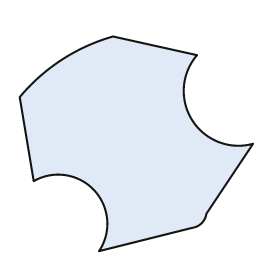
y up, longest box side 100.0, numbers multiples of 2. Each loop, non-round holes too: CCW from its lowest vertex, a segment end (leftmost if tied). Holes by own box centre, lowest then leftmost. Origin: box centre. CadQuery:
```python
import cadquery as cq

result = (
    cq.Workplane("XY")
    .moveTo(-16.0, -46.0)
    .lineTo(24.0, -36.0)
    .threePointArc((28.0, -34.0), (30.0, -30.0))
    .lineTo(50.0, 0.0)
    .threePointArc((24.0, 10.0), (26.0, 38.0))
    .lineTo(-10.0, 46.0)
    .threePointArc((-32.0, 36.0), (-50.0, 20.0))
    .lineTo(-44.0, -16.0)
    .threePointArc((-18.0, -20.0), (-16.0, -46.0))
    .close()
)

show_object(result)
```